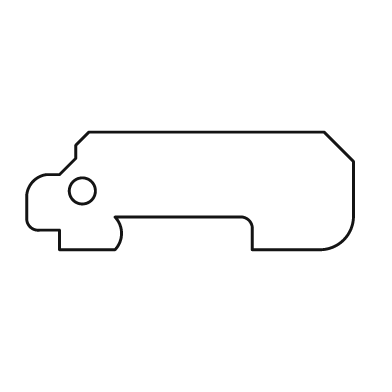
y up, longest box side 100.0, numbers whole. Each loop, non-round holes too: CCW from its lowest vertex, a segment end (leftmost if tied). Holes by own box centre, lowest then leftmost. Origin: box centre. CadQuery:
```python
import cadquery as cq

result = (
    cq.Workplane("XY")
    .moveTo(-40.0, -18.0)
    .lineTo(-23.0, -18.0)
    .threePointArc((-21.0, -13.0), (-23.0, -8.0))
    .lineTo(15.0, -8.0)
    .threePointArc((18.0, -9.0), (19.0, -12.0))
    .lineTo(19.0, -18.0)
    .lineTo(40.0, -18.0)
    .threePointArc((47.0, -15.0), (50.0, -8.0))
    .lineTo(50.0, 9.0)
    .lineTo(41.0, 18.0)
    .lineTo(-31.0, 18.0)
    .lineTo(-35.0, 14.0)
    .lineTo(-35.0, 10.0)
    .lineTo(-40.0, 5.0)
    .lineTo(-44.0, 5.0)
    .threePointArc((-48.0, 3.0), (-50.0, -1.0))
    .lineTo(-50.0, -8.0)
    .threePointArc((-49.0, -11.0), (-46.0, -12.0))
    .lineTo(-40.0, -12.0)
    .close()
    .moveTo(-33.0, 0.0)
    .circle(4.0)
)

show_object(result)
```